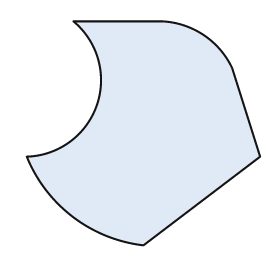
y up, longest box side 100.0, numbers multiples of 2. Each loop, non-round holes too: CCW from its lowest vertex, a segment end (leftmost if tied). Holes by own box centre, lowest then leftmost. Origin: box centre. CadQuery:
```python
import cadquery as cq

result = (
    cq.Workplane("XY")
    .moveTo(0.0, -48.0)
    .lineTo(50.0, -10.0)
    .lineTo(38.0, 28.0)
    .threePointArc((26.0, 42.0), (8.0, 48.0))
    .lineTo(-30.0, 48.0)
    .threePointArc((-20.0, 12.0), (-50.0, -10.0))
    .threePointArc((-30.0, -36.0), (0.0, -48.0))
    .close()
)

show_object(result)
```